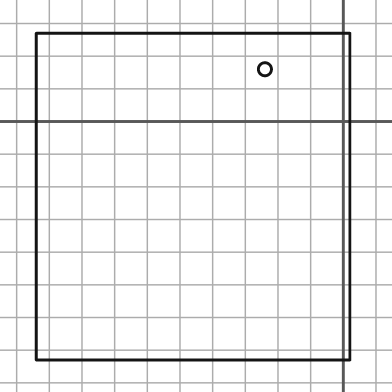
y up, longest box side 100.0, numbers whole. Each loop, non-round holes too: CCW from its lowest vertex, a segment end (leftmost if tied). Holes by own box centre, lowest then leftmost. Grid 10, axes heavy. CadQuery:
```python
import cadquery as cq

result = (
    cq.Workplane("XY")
    .moveTo(-94.0, -73.0)
    .lineTo(2.0, -73.0)
    .lineTo(2.0, 27.0)
    .lineTo(-94.0, 27.0)
    .close()
    .moveTo(-24.0, 16.0)
    .circle(2.0)
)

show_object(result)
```